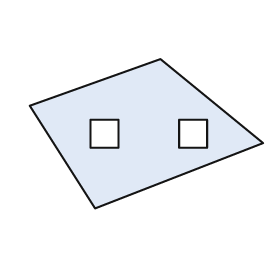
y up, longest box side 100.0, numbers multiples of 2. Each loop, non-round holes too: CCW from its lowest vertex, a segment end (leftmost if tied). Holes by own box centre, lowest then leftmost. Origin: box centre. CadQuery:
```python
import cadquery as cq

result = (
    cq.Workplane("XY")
    .moveTo(-22.0, -32.0)
    .lineTo(50.0, -4.0)
    .lineTo(6.0, 32.0)
    .lineTo(-50.0, 12.0)
    .close()
    .moveTo(-24.0, -6.0)
    .lineTo(-12.0, -6.0)
    .lineTo(-12.0, 6.0)
    .lineTo(-24.0, 6.0)
    .close()
    .moveTo(14.0, -6.0)
    .lineTo(26.0, -6.0)
    .lineTo(26.0, 6.0)
    .lineTo(14.0, 6.0)
    .close()
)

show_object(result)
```